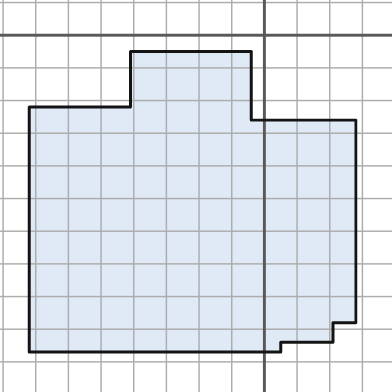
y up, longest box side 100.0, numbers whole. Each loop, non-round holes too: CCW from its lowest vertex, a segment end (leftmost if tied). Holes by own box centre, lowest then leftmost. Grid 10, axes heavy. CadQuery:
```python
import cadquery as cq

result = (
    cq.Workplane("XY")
    .moveTo(-72.0, -97.0)
    .lineTo(5.0, -97.0)
    .lineTo(5.0, -94.0)
    .lineTo(21.0, -94.0)
    .lineTo(21.0, -88.0)
    .lineTo(28.0, -88.0)
    .lineTo(28.0, -26.0)
    .lineTo(-4.0, -26.0)
    .lineTo(-4.0, -5.0)
    .lineTo(-41.0, -5.0)
    .lineTo(-41.0, -22.0)
    .lineTo(-72.0, -22.0)
    .close()
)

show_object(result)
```